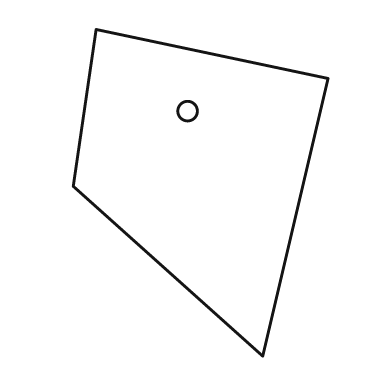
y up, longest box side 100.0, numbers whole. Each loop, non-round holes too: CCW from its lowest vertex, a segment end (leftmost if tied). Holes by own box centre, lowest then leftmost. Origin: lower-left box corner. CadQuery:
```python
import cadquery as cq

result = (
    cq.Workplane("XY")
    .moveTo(58.0, 0.0)
    .lineTo(78.0, 85.0)
    .lineTo(7.0, 100.0)
    .lineTo(0.0, 52.0)
    .close()
    .moveTo(35.0, 75.0)
    .circle(3.0)
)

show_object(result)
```